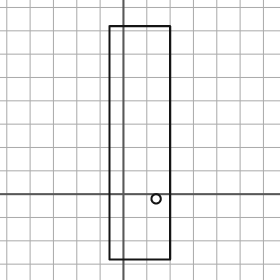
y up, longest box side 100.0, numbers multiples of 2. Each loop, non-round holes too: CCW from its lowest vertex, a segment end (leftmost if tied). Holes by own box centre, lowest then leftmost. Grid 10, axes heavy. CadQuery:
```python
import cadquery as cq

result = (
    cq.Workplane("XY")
    .moveTo(-6.0, -28.0)
    .lineTo(20.0, -28.0)
    .lineTo(20.0, 72.0)
    .lineTo(-6.0, 72.0)
    .close()
    .moveTo(14.0, -2.0)
    .circle(2.0)
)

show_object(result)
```